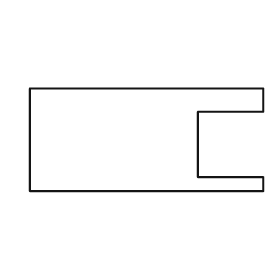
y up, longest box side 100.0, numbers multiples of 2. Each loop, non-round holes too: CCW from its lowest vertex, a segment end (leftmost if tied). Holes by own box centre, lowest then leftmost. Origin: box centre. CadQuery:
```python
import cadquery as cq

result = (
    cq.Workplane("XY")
    .moveTo(-50.0, -22.0)
    .lineTo(50.0, -22.0)
    .lineTo(50.0, -16.0)
    .lineTo(22.0, -16.0)
    .lineTo(22.0, 12.0)
    .lineTo(50.0, 12.0)
    .lineTo(50.0, 22.0)
    .lineTo(-50.0, 22.0)
    .close()
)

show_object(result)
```